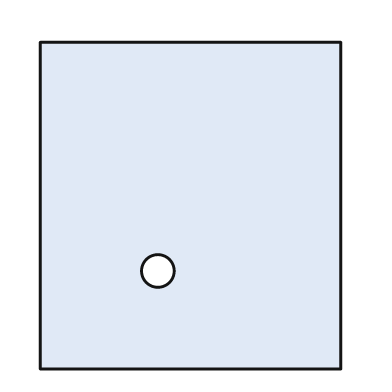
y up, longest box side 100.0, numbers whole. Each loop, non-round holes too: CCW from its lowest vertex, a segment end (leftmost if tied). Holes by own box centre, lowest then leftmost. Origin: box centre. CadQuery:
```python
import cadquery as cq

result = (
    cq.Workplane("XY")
    .moveTo(-46.0, -50.0)
    .lineTo(46.0, -50.0)
    .lineTo(46.0, 50.0)
    .lineTo(-46.0, 50.0)
    .close()
    .moveTo(-10.0, -20.0)
    .circle(5.0)
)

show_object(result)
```